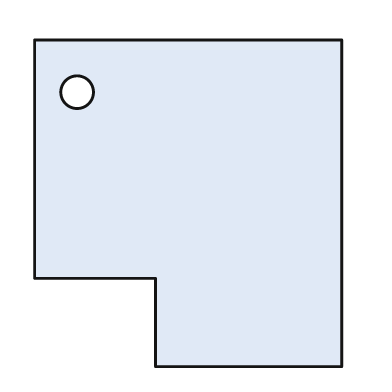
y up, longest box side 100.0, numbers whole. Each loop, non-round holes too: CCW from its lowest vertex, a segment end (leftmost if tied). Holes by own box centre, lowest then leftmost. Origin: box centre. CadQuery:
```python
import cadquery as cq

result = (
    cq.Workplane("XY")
    .moveTo(-10.0, -50.0)
    .lineTo(47.0, -50.0)
    .lineTo(47.0, 50.0)
    .lineTo(-47.0, 50.0)
    .lineTo(-47.0, -23.0)
    .lineTo(-10.0, -23.0)
    .close()
    .moveTo(-34.0, 34.0)
    .circle(5.0)
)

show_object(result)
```